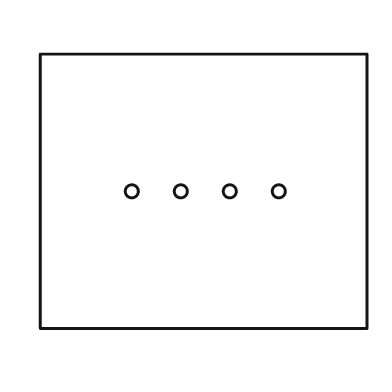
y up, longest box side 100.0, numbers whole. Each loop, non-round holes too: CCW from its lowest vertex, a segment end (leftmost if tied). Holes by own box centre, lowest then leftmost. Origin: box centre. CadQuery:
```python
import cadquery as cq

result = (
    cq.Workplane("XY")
    .moveTo(-50.0, -42.0)
    .lineTo(50.0, -42.0)
    .lineTo(50.0, 42.0)
    .lineTo(-50.0, 42.0)
    .close()
    .moveTo(-22.0, 0.0)
    .circle(2.0)
    .moveTo(-7.0, 0.0)
    .circle(2.0)
    .moveTo(8.0, 0.0)
    .circle(2.0)
    .moveTo(23.0, 0.0)
    .circle(2.0)
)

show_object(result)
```